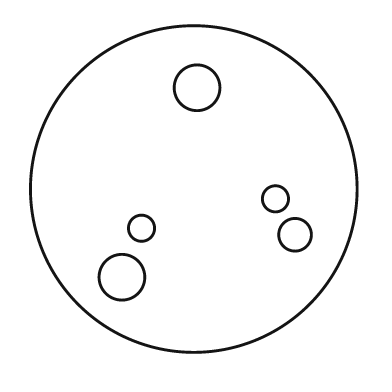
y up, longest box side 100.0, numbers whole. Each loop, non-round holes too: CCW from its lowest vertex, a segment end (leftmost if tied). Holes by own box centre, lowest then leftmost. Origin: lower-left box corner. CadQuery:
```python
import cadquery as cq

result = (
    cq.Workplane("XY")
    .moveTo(50.0, 50.0)
    .circle(50.0)
    .moveTo(28.0, 23.0)
    .circle(7.0)
    .moveTo(81.0, 36.0)
    .circle(5.0)
    .moveTo(34.0, 38.0)
    .circle(4.0)
    .moveTo(75.0, 47.0)
    .circle(4.0)
    .moveTo(51.0, 81.0)
    .circle(7.0)
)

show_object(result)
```